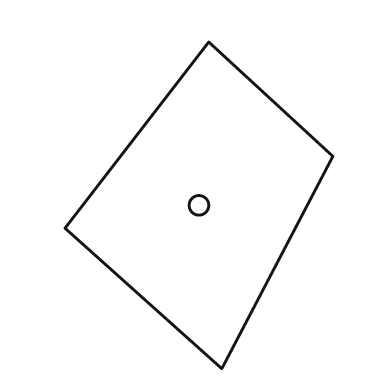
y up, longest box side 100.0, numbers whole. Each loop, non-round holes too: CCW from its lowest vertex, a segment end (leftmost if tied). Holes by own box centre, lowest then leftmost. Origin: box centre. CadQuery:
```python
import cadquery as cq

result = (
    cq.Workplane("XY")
    .moveTo(7.0, -50.0)
    .lineTo(41.0, 15.0)
    .lineTo(3.0, 50.0)
    .lineTo(-41.0, -7.0)
    .close()
    .moveTo(0.0, 0.0)
    .circle(3.0)
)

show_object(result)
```